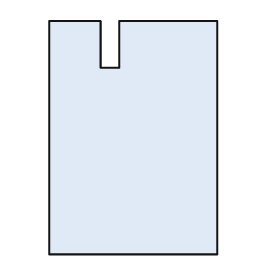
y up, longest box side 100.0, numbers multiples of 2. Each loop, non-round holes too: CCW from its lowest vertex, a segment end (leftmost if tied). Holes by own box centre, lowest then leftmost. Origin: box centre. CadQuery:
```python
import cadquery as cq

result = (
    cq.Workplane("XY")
    .moveTo(-36.0, -50.0)
    .lineTo(36.0, -50.0)
    .lineTo(36.0, 50.0)
    .lineTo(-6.0, 50.0)
    .lineTo(-6.0, 30.0)
    .lineTo(-14.0, 30.0)
    .lineTo(-14.0, 50.0)
    .lineTo(-36.0, 50.0)
    .close()
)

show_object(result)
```